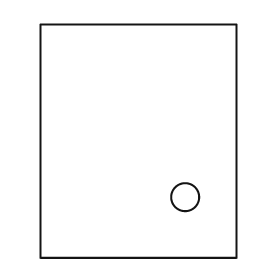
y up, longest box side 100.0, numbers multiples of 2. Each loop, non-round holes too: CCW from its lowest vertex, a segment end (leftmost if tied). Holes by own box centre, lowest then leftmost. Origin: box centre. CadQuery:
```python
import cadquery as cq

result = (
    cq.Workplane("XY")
    .moveTo(-42.0, -50.0)
    .lineTo(42.0, -50.0)
    .lineTo(42.0, 50.0)
    .lineTo(-42.0, 50.0)
    .close()
    .moveTo(20.0, -24.0)
    .circle(6.0)
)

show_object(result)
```